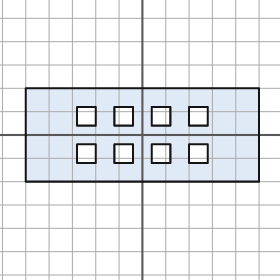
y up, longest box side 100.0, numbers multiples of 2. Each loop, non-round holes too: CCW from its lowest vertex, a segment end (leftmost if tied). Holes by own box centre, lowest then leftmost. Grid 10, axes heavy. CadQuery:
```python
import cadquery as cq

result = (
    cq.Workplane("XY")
    .moveTo(-50.0, -20.0)
    .lineTo(50.0, -20.0)
    .lineTo(50.0, 20.0)
    .lineTo(-50.0, 20.0)
    .close()
    .moveTo(-28.0, -12.0)
    .lineTo(-20.0, -12.0)
    .lineTo(-20.0, -4.0)
    .lineTo(-28.0, -4.0)
    .close()
    .moveTo(-12.0, -12.0)
    .lineTo(-4.0, -12.0)
    .lineTo(-4.0, -4.0)
    .lineTo(-12.0, -4.0)
    .close()
    .moveTo(4.0, -12.0)
    .lineTo(12.0, -12.0)
    .lineTo(12.0, -4.0)
    .lineTo(4.0, -4.0)
    .close()
    .moveTo(20.0, -12.0)
    .lineTo(28.0, -12.0)
    .lineTo(28.0, -4.0)
    .lineTo(20.0, -4.0)
    .close()
    .moveTo(-28.0, 4.0)
    .lineTo(-20.0, 4.0)
    .lineTo(-20.0, 12.0)
    .lineTo(-28.0, 12.0)
    .close()
    .moveTo(-12.0, 4.0)
    .lineTo(-4.0, 4.0)
    .lineTo(-4.0, 12.0)
    .lineTo(-12.0, 12.0)
    .close()
    .moveTo(4.0, 4.0)
    .lineTo(12.0, 4.0)
    .lineTo(12.0, 12.0)
    .lineTo(4.0, 12.0)
    .close()
    .moveTo(20.0, 4.0)
    .lineTo(28.0, 4.0)
    .lineTo(28.0, 12.0)
    .lineTo(20.0, 12.0)
    .close()
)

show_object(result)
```